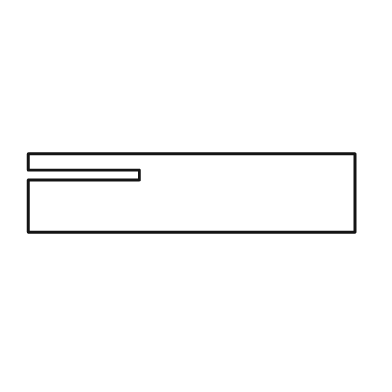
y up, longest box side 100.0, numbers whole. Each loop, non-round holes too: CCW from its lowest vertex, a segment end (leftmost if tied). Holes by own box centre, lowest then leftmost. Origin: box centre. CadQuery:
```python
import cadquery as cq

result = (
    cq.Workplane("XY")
    .moveTo(-50.0, -12.0)
    .lineTo(50.0, -12.0)
    .lineTo(50.0, 12.0)
    .lineTo(-50.0, 12.0)
    .lineTo(-50.0, 7.0)
    .lineTo(-16.0, 7.0)
    .lineTo(-16.0, 4.0)
    .lineTo(-50.0, 4.0)
    .close()
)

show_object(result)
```